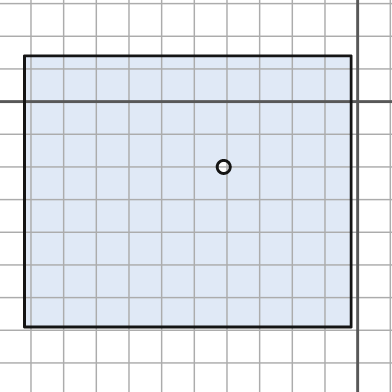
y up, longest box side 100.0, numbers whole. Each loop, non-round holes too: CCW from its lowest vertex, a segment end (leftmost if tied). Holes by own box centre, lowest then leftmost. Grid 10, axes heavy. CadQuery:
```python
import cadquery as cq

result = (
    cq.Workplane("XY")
    .moveTo(-102.0, -69.0)
    .lineTo(-2.0, -69.0)
    .lineTo(-2.0, 14.0)
    .lineTo(-102.0, 14.0)
    .close()
    .moveTo(-41.0, -20.0)
    .circle(2.0)
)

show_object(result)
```